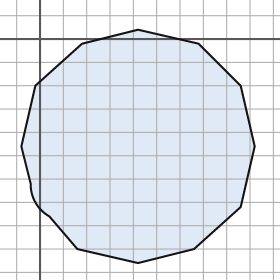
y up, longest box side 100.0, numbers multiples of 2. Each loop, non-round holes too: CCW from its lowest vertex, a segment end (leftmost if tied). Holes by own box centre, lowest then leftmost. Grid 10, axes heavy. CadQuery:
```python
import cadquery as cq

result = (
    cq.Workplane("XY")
    .moveTo(42.0, -96.0)
    .lineTo(66.0, -90.0)
    .lineTo(86.0, -72.0)
    .lineTo(92.0, -46.0)
    .lineTo(86.0, -20.0)
    .lineTo(68.0, -2.0)
    .lineTo(42.0, 4.0)
    .lineTo(18.0, -2.0)
    .lineTo(-2.0, -20.0)
    .lineTo(-8.0, -46.0)
    .lineTo(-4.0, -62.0)
    .threePointArc((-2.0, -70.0), (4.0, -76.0))
    .lineTo(16.0, -90.0)
    .close()
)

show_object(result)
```